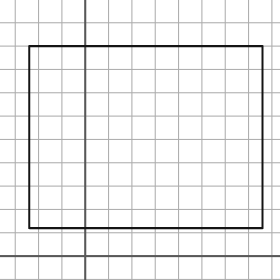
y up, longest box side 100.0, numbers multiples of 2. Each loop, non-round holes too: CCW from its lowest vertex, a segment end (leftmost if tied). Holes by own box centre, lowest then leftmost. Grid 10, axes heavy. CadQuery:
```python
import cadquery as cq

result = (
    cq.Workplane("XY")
    .moveTo(-24.0, 12.0)
    .lineTo(76.0, 12.0)
    .lineTo(76.0, 90.0)
    .lineTo(-24.0, 90.0)
    .close()
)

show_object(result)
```